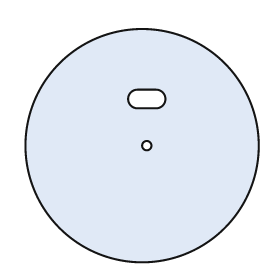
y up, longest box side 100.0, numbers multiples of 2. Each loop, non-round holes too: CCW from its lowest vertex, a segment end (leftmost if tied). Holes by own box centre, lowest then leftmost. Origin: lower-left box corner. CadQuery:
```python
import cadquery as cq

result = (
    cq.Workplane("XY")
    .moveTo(50.0, 50.0)
    .circle(50.0)
    .moveTo(52.0, 50.0)
    .circle(2.0)
    .moveTo(48.0, 66.0)
    .lineTo(56.0, 66.0)
    .threePointArc((60.0, 70.0), (56.0, 74.0))
    .lineTo(48.0, 74.0)
    .threePointArc((44.0, 70.0), (48.0, 66.0))
    .close()
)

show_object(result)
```